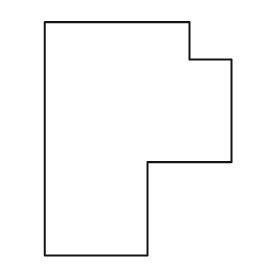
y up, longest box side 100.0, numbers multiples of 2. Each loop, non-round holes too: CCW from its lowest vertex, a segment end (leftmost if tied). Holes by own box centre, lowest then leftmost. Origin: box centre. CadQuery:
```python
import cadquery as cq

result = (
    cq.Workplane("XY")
    .moveTo(-40.0, -50.0)
    .lineTo(4.0, -50.0)
    .lineTo(4.0, -10.0)
    .lineTo(40.0, -10.0)
    .lineTo(40.0, 34.0)
    .lineTo(22.0, 34.0)
    .lineTo(22.0, 50.0)
    .lineTo(-40.0, 50.0)
    .close()
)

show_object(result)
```